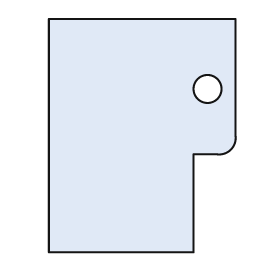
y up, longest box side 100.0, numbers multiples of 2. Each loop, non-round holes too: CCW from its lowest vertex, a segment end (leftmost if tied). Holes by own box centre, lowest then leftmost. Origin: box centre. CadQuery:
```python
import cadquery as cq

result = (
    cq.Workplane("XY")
    .moveTo(-40.0, -50.0)
    .lineTo(22.0, -50.0)
    .lineTo(22.0, -8.0)
    .lineTo(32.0, -8.0)
    .threePointArc((38.0, -6.0), (40.0, 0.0))
    .lineTo(40.0, 50.0)
    .lineTo(-40.0, 50.0)
    .close()
    .moveTo(28.0, 20.0)
    .circle(6.0)
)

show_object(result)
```